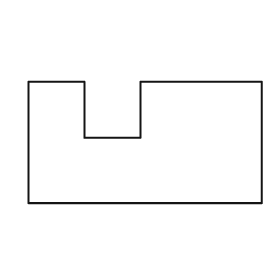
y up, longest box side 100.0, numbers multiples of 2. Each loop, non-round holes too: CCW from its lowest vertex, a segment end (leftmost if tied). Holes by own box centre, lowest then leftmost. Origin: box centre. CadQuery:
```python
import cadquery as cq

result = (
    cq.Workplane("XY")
    .moveTo(-50.0, -26.0)
    .lineTo(50.0, -26.0)
    .lineTo(50.0, 26.0)
    .lineTo(-2.0, 26.0)
    .lineTo(-2.0, 2.0)
    .lineTo(-26.0, 2.0)
    .lineTo(-26.0, 26.0)
    .lineTo(-50.0, 26.0)
    .close()
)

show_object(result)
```